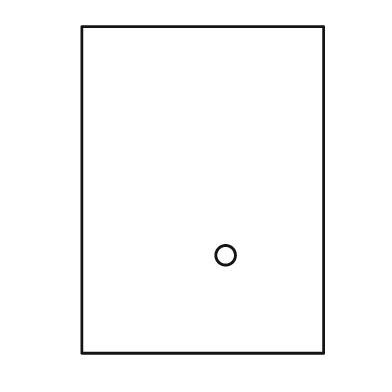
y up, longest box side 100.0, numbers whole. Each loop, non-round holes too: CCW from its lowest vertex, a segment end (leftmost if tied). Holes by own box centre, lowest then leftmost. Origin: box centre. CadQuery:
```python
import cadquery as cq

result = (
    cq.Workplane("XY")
    .moveTo(-37.0, -50.0)
    .lineTo(37.0, -50.0)
    .lineTo(37.0, 50.0)
    .lineTo(-37.0, 50.0)
    .close()
    .moveTo(7.0, -20.0)
    .circle(3.0)
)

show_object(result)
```